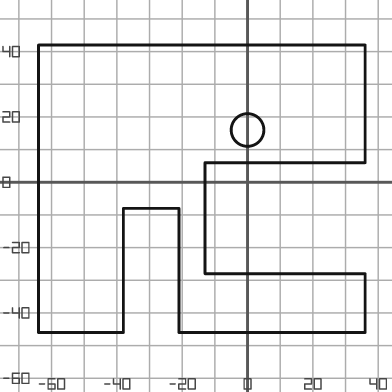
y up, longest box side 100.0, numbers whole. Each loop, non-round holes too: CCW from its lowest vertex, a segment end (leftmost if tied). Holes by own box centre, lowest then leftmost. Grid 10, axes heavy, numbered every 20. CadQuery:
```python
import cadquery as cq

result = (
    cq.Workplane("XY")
    .moveTo(-64.0, -46.0)
    .lineTo(-38.0, -46.0)
    .lineTo(-38.0, -8.0)
    .lineTo(-21.0, -8.0)
    .lineTo(-21.0, -46.0)
    .lineTo(36.0, -46.0)
    .lineTo(36.0, -28.0)
    .lineTo(-13.0, -28.0)
    .lineTo(-13.0, 6.0)
    .lineTo(36.0, 6.0)
    .lineTo(36.0, 42.0)
    .lineTo(-64.0, 42.0)
    .close()
    .moveTo(0.0, 16.0)
    .circle(5.0)
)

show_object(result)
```